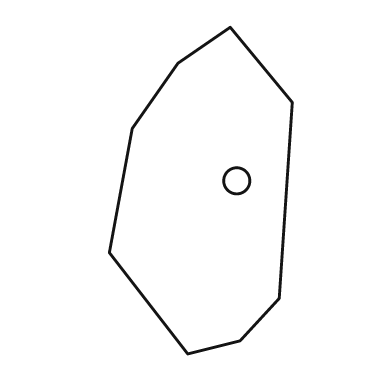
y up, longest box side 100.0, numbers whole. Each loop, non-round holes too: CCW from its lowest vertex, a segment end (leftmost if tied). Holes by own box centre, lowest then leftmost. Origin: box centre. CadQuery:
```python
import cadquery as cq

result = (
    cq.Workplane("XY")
    .moveTo(-4.0, -50.0)
    .lineTo(12.0, -46.0)
    .lineTo(24.0, -33.0)
    .lineTo(28.0, 27.0)
    .lineTo(9.0, 50.0)
    .lineTo(-7.0, 39.0)
    .lineTo(-21.0, 19.0)
    .lineTo(-28.0, -19.0)
    .close()
    .moveTo(11.0, 3.0)
    .circle(4.0)
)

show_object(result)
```